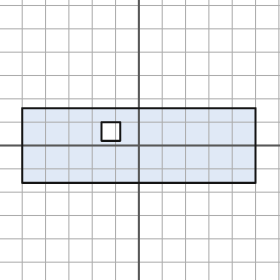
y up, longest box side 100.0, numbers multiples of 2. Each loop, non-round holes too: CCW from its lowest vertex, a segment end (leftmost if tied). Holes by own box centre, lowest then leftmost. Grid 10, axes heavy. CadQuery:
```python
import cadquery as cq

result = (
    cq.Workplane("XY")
    .moveTo(-50.0, -16.0)
    .lineTo(50.0, -16.0)
    .lineTo(50.0, 16.0)
    .lineTo(-50.0, 16.0)
    .close()
    .moveTo(-16.0, 2.0)
    .lineTo(-8.0, 2.0)
    .lineTo(-8.0, 10.0)
    .lineTo(-16.0, 10.0)
    .close()
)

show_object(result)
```